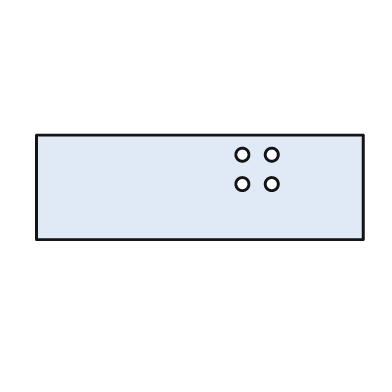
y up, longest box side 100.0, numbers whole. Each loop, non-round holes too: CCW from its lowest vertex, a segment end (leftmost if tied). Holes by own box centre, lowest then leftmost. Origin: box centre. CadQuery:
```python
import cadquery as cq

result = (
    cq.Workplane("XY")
    .moveTo(-50.0, -16.0)
    .lineTo(50.0, -16.0)
    .lineTo(50.0, 16.0)
    .lineTo(-50.0, 16.0)
    .close()
    .moveTo(13.0, 1.0)
    .circle(2.0)
    .moveTo(22.0, 1.0)
    .circle(2.0)
    .moveTo(13.0, 10.0)
    .circle(2.0)
    .moveTo(22.0, 10.0)
    .circle(2.0)
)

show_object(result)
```